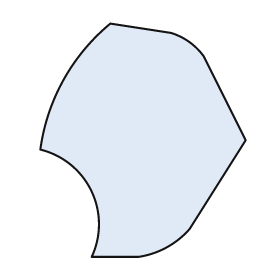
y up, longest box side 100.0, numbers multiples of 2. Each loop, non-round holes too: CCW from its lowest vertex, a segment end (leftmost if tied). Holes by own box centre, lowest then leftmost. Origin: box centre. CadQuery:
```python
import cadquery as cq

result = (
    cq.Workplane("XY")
    .moveTo(-22.0, -50.0)
    .lineTo(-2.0, -50.0)
    .threePointArc((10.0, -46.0), (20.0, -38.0))
    .lineTo(44.0, 0.0)
    .lineTo(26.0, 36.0)
    .threePointArc((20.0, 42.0), (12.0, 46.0))
    .lineTo(-14.0, 50.0)
    .threePointArc((-34.0, 26.0), (-44.0, -4.0))
    .threePointArc((-22.0, -22.0), (-22.0, -50.0))
    .close()
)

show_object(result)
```